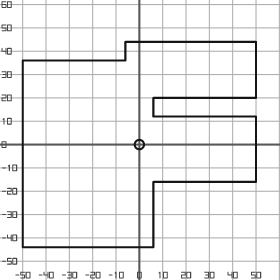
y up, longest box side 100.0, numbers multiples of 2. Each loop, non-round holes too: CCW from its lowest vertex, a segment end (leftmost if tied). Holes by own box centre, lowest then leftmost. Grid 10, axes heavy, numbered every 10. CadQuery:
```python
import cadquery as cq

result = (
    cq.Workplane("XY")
    .moveTo(-50.0, -44.0)
    .lineTo(6.0, -44.0)
    .lineTo(6.0, -16.0)
    .lineTo(50.0, -16.0)
    .lineTo(50.0, 12.0)
    .lineTo(6.0, 12.0)
    .lineTo(6.0, 20.0)
    .lineTo(50.0, 20.0)
    .lineTo(50.0, 44.0)
    .lineTo(-6.0, 44.0)
    .lineTo(-6.0, 36.0)
    .lineTo(-50.0, 36.0)
    .close()
    .moveTo(0.0, 0.0)
    .circle(2.0)
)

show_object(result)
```